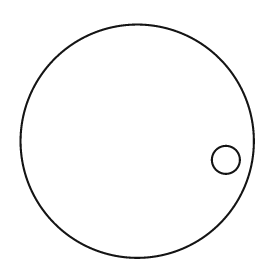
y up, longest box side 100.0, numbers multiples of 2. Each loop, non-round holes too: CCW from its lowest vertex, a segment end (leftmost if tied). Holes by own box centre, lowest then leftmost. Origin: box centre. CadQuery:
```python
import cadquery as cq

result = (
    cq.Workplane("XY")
    .moveTo(0.0, 0.0)
    .circle(50.0)
    .moveTo(38.0, -8.0)
    .circle(6.0)
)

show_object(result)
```